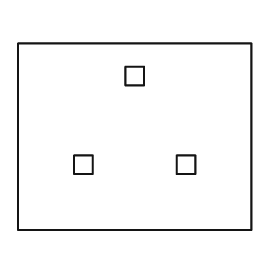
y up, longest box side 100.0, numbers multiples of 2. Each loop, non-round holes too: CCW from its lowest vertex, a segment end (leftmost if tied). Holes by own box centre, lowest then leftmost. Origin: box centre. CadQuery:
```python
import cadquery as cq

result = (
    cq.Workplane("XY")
    .moveTo(-50.0, -40.0)
    .lineTo(50.0, -40.0)
    .lineTo(50.0, 40.0)
    .lineTo(-50.0, 40.0)
    .close()
    .moveTo(-26.0, -16.0)
    .lineTo(-18.0, -16.0)
    .lineTo(-18.0, -8.0)
    .lineTo(-26.0, -8.0)
    .close()
    .moveTo(18.0, -16.0)
    .lineTo(26.0, -16.0)
    .lineTo(26.0, -8.0)
    .lineTo(18.0, -8.0)
    .close()
    .moveTo(-4.0, 22.0)
    .lineTo(4.0, 22.0)
    .lineTo(4.0, 30.0)
    .lineTo(-4.0, 30.0)
    .close()
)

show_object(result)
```